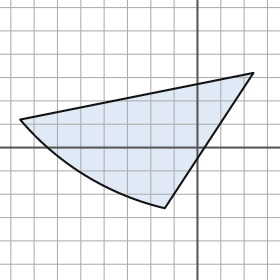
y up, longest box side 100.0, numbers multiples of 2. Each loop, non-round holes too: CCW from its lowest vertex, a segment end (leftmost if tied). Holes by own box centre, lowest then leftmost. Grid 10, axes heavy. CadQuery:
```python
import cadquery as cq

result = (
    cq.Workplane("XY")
    .moveTo(-14.0, -26.0)
    .lineTo(24.0, 32.0)
    .lineTo(-76.0, 12.0)
    .threePointArc((-48.0, -12.0), (-14.0, -26.0))
    .close()
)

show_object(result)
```